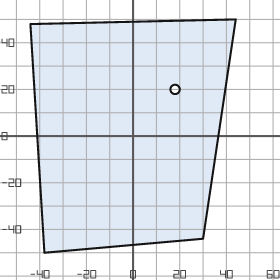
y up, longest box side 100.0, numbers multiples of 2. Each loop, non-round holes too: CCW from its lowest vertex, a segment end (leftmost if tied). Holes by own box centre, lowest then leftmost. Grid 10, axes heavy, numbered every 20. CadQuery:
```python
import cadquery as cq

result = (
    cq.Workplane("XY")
    .moveTo(-38.0, -50.0)
    .lineTo(30.0, -44.0)
    .lineTo(44.0, 50.0)
    .lineTo(-44.0, 48.0)
    .close()
    .moveTo(18.0, 20.0)
    .circle(2.0)
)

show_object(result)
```